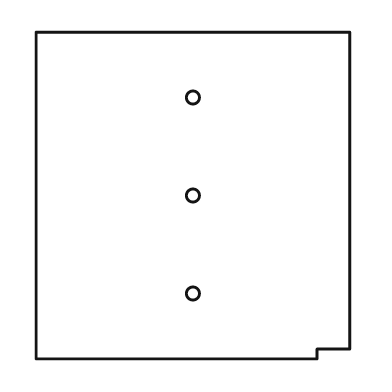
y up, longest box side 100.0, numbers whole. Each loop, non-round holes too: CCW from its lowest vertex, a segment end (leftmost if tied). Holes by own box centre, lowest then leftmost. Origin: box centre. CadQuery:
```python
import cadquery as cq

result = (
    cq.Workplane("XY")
    .moveTo(-48.0, -50.0)
    .lineTo(38.0, -50.0)
    .lineTo(38.0, -47.0)
    .lineTo(48.0, -47.0)
    .lineTo(48.0, 50.0)
    .lineTo(-48.0, 50.0)
    .close()
    .moveTo(0.0, -30.0)
    .circle(2.0)
    .moveTo(0.0, 0.0)
    .circle(2.0)
    .moveTo(0.0, 30.0)
    .circle(2.0)
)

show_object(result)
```